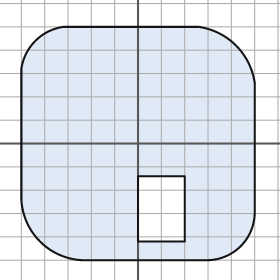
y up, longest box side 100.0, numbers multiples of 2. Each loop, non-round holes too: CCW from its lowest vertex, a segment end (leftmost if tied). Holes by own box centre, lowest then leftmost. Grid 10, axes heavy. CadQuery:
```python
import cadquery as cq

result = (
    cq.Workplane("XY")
    .moveTo(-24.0, -50.0)
    .lineTo(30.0, -50.0)
    .threePointArc((44.0, -44.0), (50.0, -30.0))
    .lineTo(50.0, 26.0)
    .threePointArc((42.0, 42.0), (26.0, 50.0))
    .lineTo(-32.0, 50.0)
    .threePointArc((-44.0, 44.0), (-50.0, 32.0))
    .lineTo(-50.0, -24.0)
    .threePointArc((-42.0, -42.0), (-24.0, -50.0))
    .close()
    .moveTo(0.0, -42.0)
    .lineTo(20.0, -42.0)
    .lineTo(20.0, -14.0)
    .lineTo(0.0, -14.0)
    .close()
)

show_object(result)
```